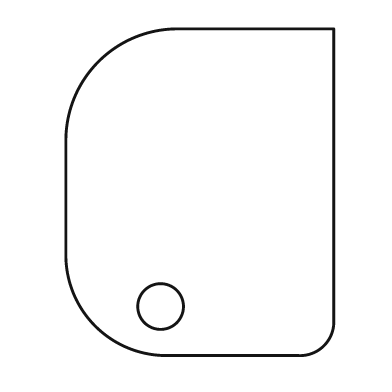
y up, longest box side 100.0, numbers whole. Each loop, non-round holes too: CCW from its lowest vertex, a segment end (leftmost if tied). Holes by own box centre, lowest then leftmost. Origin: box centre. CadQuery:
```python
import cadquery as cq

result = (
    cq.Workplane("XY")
    .moveTo(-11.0, -50.0)
    .lineTo(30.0, -50.0)
    .threePointArc((38.0, -47.0), (41.0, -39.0))
    .lineTo(41.0, 50.0)
    .lineTo(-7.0, 50.0)
    .threePointArc((-31.0, 40.0), (-41.0, 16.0))
    .lineTo(-41.0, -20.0)
    .threePointArc((-32.0, -41.0), (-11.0, -50.0))
    .close()
    .moveTo(-12.0, -35.0)
    .circle(7.0)
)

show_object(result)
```